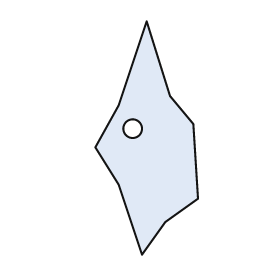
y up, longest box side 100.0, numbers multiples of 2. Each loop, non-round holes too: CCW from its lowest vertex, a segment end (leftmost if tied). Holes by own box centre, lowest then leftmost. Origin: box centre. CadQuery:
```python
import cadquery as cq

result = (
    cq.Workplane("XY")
    .moveTo(-2.0, -50.0)
    .lineTo(8.0, -36.0)
    .lineTo(22.0, -26.0)
    .lineTo(20.0, 6.0)
    .lineTo(10.0, 18.0)
    .lineTo(0.0, 50.0)
    .lineTo(-12.0, 14.0)
    .lineTo(-22.0, -4.0)
    .lineTo(-12.0, -20.0)
    .close()
    .moveTo(-6.0, 4.0)
    .circle(4.0)
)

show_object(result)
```